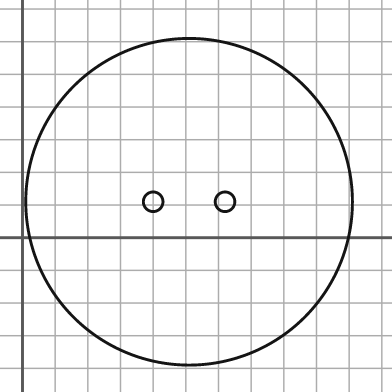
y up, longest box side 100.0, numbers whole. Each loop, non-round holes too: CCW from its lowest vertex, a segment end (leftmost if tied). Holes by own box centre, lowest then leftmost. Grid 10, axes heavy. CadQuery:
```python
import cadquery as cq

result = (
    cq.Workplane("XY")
    .moveTo(51.0, 11.0)
    .circle(50.0)
    .moveTo(40.0, 11.0)
    .circle(3.0)
    .moveTo(62.0, 11.0)
    .circle(3.0)
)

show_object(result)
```